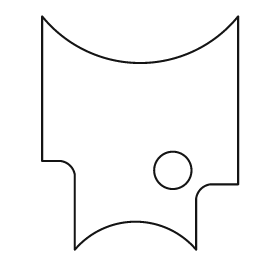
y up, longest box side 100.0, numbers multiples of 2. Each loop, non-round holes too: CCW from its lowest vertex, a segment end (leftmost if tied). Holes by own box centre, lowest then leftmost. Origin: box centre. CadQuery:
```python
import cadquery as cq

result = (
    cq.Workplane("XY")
    .moveTo(-28.0, -50.0)
    .threePointArc((-2.0, -38.0), (24.0, -50.0))
    .lineTo(24.0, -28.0)
    .threePointArc((26.0, -24.0), (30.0, -22.0))
    .lineTo(42.0, -22.0)
    .lineTo(42.0, 50.0)
    .threePointArc((0.0, 30.0), (-42.0, 50.0))
    .lineTo(-42.0, -12.0)
    .lineTo(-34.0, -12.0)
    .threePointArc((-30.0, -14.0), (-28.0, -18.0))
    .close()
    .moveTo(14.0, -16.0)
    .circle(8.0)
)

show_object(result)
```